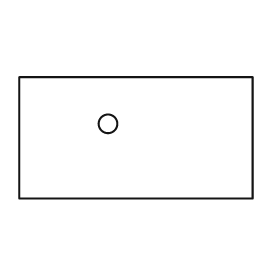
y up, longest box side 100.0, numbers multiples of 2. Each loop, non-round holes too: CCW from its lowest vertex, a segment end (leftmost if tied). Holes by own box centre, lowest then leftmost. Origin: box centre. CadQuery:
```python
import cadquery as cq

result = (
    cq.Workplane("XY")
    .moveTo(-50.0, -26.0)
    .lineTo(50.0, -26.0)
    .lineTo(50.0, 26.0)
    .lineTo(-50.0, 26.0)
    .close()
    .moveTo(-12.0, 6.0)
    .circle(4.0)
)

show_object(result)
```